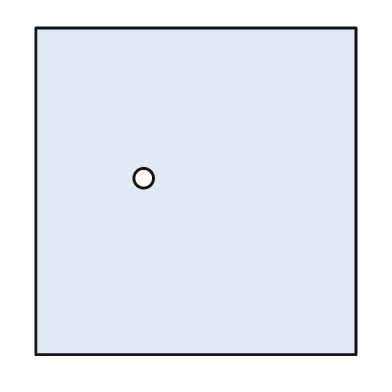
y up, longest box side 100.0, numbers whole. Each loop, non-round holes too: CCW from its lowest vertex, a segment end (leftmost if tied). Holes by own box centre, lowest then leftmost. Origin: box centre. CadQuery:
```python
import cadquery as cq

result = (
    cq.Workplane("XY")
    .moveTo(-49.0, -50.0)
    .lineTo(49.0, -50.0)
    .lineTo(49.0, 50.0)
    .lineTo(-49.0, 50.0)
    .close()
    .moveTo(-16.0, 4.0)
    .circle(3.0)
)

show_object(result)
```